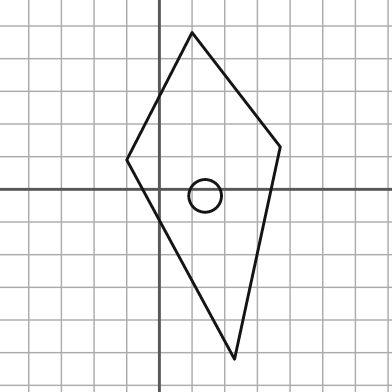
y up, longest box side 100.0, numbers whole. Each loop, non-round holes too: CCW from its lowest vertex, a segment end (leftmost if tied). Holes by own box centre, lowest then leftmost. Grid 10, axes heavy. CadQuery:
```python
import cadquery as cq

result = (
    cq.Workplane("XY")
    .moveTo(23.0, -52.0)
    .lineTo(37.0, 13.0)
    .lineTo(10.0, 48.0)
    .lineTo(-10.0, 9.0)
    .close()
    .moveTo(14.0, -2.0)
    .circle(5.0)
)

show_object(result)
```